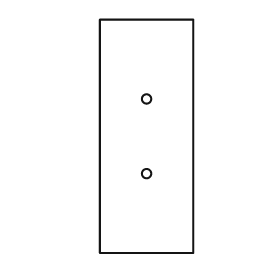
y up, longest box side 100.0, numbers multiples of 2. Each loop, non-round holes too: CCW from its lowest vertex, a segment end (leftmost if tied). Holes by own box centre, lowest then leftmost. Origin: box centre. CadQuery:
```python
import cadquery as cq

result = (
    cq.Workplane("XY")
    .moveTo(-20.0, -50.0)
    .lineTo(20.0, -50.0)
    .lineTo(20.0, 50.0)
    .lineTo(-20.0, 50.0)
    .close()
    .moveTo(0.0, -16.0)
    .circle(2.0)
    .moveTo(0.0, 16.0)
    .circle(2.0)
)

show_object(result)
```